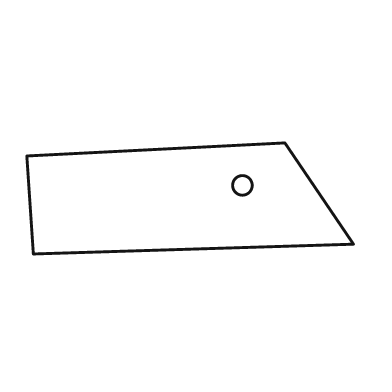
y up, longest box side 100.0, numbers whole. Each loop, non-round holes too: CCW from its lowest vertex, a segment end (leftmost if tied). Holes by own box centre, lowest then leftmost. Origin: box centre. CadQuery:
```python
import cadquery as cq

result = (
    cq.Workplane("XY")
    .moveTo(-48.0, -17.0)
    .lineTo(50.0, -14.0)
    .lineTo(29.0, 17.0)
    .lineTo(-50.0, 13.0)
    .close()
    .moveTo(16.0, 4.0)
    .circle(3.0)
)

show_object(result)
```